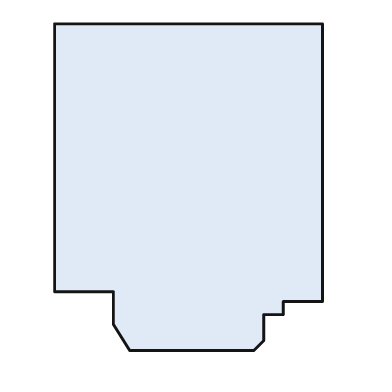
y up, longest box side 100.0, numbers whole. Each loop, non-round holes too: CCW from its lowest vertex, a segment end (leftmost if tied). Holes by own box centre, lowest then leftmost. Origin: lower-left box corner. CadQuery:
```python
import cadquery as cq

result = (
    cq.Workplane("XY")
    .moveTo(23.0, 0.0)
    .lineTo(61.0, 0.0)
    .lineTo(64.0, 3.0)
    .lineTo(64.0, 11.0)
    .lineTo(70.0, 11.0)
    .lineTo(70.0, 15.0)
    .lineTo(82.0, 15.0)
    .lineTo(82.0, 100.0)
    .lineTo(0.0, 100.0)
    .lineTo(0.0, 18.0)
    .lineTo(18.0, 18.0)
    .lineTo(18.0, 8.0)
    .close()
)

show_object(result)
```